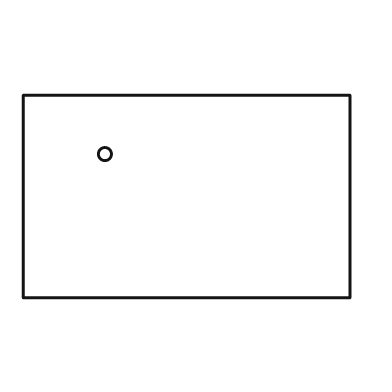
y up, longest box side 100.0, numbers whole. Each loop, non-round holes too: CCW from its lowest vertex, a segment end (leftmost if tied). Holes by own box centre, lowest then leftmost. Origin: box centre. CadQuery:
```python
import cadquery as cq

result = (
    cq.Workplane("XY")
    .moveTo(-50.0, -31.0)
    .lineTo(50.0, -31.0)
    .lineTo(50.0, 31.0)
    .lineTo(-50.0, 31.0)
    .close()
    .moveTo(-25.0, 13.0)
    .circle(2.0)
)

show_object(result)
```